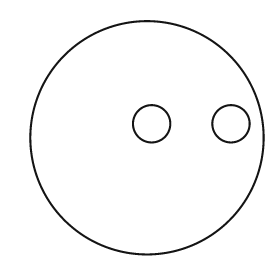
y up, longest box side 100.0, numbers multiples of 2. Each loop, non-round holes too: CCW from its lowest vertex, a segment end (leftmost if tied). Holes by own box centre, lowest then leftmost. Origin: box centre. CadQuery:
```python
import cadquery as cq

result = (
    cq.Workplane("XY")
    .moveTo(0.0, 0.0)
    .circle(50.0)
    .moveTo(2.0, 6.0)
    .circle(8.0)
    .moveTo(36.0, 6.0)
    .circle(8.0)
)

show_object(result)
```